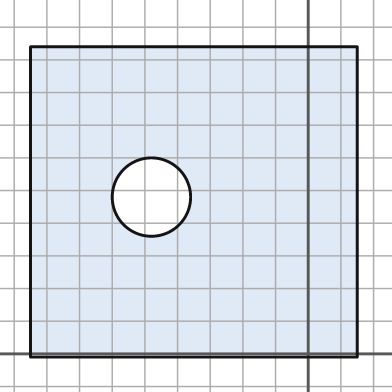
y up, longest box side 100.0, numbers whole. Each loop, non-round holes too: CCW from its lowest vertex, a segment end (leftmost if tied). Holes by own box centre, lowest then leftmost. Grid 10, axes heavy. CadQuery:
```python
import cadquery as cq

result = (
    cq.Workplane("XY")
    .moveTo(-85.0, -1.0)
    .lineTo(15.0, -1.0)
    .lineTo(15.0, 94.0)
    .lineTo(-85.0, 94.0)
    .close()
    .moveTo(-48.0, 48.0)
    .circle(12.0)
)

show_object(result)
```